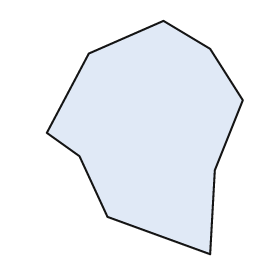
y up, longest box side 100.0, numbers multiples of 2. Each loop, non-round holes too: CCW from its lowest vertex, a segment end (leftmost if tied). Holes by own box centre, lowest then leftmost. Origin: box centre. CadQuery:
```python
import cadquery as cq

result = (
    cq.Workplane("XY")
    .moveTo(28.0, -50.0)
    .lineTo(30.0, -14.0)
    .lineTo(42.0, 16.0)
    .lineTo(28.0, 38.0)
    .lineTo(8.0, 50.0)
    .lineTo(-24.0, 36.0)
    .lineTo(-42.0, 2.0)
    .lineTo(-28.0, -8.0)
    .lineTo(-16.0, -34.0)
    .close()
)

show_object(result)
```